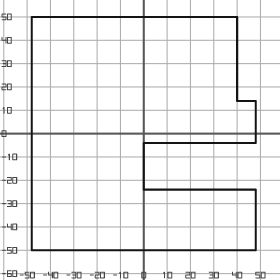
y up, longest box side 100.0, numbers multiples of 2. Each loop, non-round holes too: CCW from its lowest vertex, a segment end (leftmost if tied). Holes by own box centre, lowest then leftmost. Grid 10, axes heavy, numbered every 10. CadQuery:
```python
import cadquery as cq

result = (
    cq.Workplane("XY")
    .moveTo(-48.0, -50.0)
    .lineTo(48.0, -50.0)
    .lineTo(48.0, -24.0)
    .lineTo(0.0, -24.0)
    .lineTo(0.0, -4.0)
    .lineTo(48.0, -4.0)
    .lineTo(48.0, 14.0)
    .lineTo(40.0, 14.0)
    .lineTo(40.0, 50.0)
    .lineTo(-48.0, 50.0)
    .close()
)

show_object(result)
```